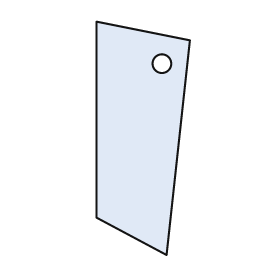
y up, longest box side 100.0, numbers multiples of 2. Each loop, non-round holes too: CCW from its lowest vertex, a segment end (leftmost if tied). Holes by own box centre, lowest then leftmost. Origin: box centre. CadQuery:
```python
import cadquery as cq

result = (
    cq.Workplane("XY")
    .moveTo(10.0, -50.0)
    .lineTo(20.0, 42.0)
    .lineTo(-20.0, 50.0)
    .lineTo(-20.0, -34.0)
    .close()
    .moveTo(8.0, 32.0)
    .circle(4.0)
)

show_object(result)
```